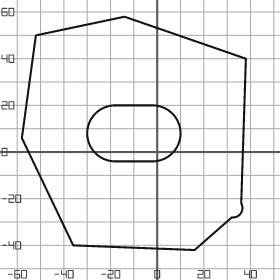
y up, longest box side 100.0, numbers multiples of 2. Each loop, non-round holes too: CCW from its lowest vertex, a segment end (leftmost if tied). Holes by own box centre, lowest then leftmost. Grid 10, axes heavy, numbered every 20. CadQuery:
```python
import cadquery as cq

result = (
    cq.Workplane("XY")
    .moveTo(16.0, -42.0)
    .lineTo(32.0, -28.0)
    .threePointArc((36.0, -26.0), (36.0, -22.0))
    .lineTo(38.0, 40.0)
    .lineTo(-14.0, 58.0)
    .lineTo(-52.0, 50.0)
    .lineTo(-58.0, 6.0)
    .lineTo(-36.0, -40.0)
    .close()
    .moveTo(-18.0, -4.0)
    .lineTo(-2.0, -4.0)
    .threePointArc((10.0, 8.0), (-2.0, 20.0))
    .lineTo(-18.0, 20.0)
    .threePointArc((-30.0, 8.0), (-18.0, -4.0))
    .close()
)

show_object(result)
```